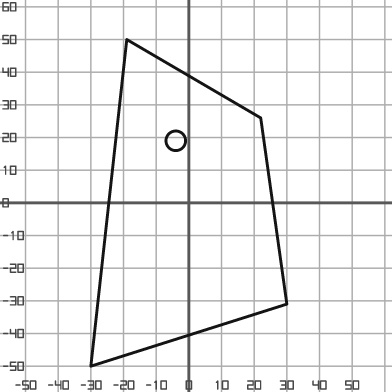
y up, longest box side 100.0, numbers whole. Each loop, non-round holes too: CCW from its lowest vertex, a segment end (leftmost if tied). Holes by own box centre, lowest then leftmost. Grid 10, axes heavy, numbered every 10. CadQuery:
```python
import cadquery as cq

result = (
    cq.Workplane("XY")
    .moveTo(-30.0, -50.0)
    .lineTo(30.0, -31.0)
    .lineTo(22.0, 26.0)
    .lineTo(-19.0, 50.0)
    .close()
    .moveTo(-4.0, 19.0)
    .circle(3.0)
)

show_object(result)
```